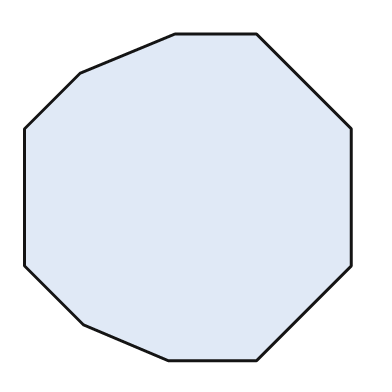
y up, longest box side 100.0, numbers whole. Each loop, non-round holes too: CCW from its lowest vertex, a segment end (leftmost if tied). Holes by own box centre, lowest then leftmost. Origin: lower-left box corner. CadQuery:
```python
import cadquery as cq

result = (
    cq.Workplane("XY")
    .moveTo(44.0, 0.0)
    .lineTo(71.0, 0.0)
    .lineTo(100.0, 29.0)
    .lineTo(100.0, 71.0)
    .lineTo(71.0, 100.0)
    .lineTo(46.0, 100.0)
    .lineTo(17.0, 88.0)
    .lineTo(0.0, 71.0)
    .lineTo(0.0, 29.0)
    .lineTo(18.0, 11.0)
    .close()
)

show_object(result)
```